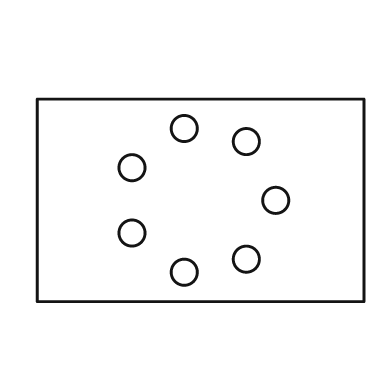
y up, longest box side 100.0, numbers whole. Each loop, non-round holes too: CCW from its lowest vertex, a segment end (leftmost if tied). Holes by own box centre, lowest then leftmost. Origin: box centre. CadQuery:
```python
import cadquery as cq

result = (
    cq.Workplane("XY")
    .moveTo(-50.0, -31.0)
    .lineTo(50.0, -31.0)
    .lineTo(50.0, 31.0)
    .lineTo(-50.0, 31.0)
    .close()
    .moveTo(-5.0, -22.0)
    .circle(4.0)
    .moveTo(14.0, -18.0)
    .circle(4.0)
    .moveTo(-21.0, -10.0)
    .circle(4.0)
    .moveTo(23.0, 0.0)
    .circle(4.0)
    .moveTo(-21.0, 10.0)
    .circle(4.0)
    .moveTo(14.0, 18.0)
    .circle(4.0)
    .moveTo(-5.0, 22.0)
    .circle(4.0)
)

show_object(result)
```